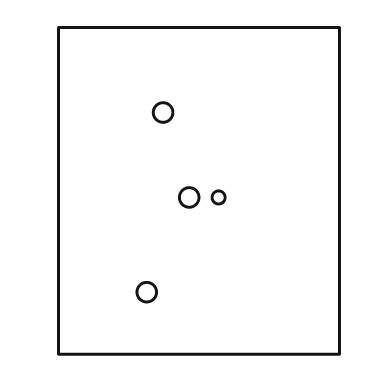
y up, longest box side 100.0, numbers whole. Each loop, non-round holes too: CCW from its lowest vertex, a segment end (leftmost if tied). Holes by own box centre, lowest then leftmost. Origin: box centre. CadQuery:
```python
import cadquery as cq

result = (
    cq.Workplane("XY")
    .moveTo(-43.0, -50.0)
    .lineTo(43.0, -50.0)
    .lineTo(43.0, 50.0)
    .lineTo(-43.0, 50.0)
    .close()
    .moveTo(-16.0, -31.0)
    .circle(3.0)
    .moveTo(-3.0, -2.0)
    .circle(3.0)
    .moveTo(6.0, -2.0)
    .circle(2.0)
    .moveTo(-11.0, 24.0)
    .circle(3.0)
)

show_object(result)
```